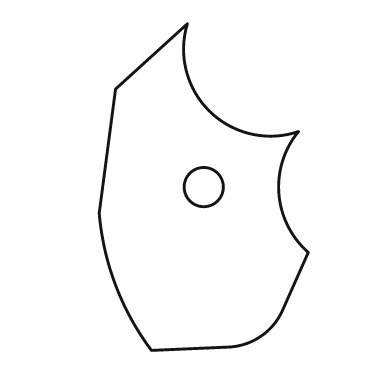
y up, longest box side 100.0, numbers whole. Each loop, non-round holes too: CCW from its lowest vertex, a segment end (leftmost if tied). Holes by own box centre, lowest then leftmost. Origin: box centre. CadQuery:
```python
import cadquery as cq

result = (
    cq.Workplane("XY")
    .moveTo(-16.0, -50.0)
    .lineTo(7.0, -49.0)
    .threePointArc((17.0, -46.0), (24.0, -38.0))
    .lineTo(32.0, -20.0)
    .threePointArc((23.0, -2.0), (29.0, 17.0))
    .threePointArc((2.0, 23.0), (-5.0, 50.0))
    .lineTo(-27.0, 30.0)
    .lineTo(-32.0, -8.0)
    .threePointArc((-27.0, -30.0), (-16.0, -50.0))
    .close()
    .moveTo(0.0, 0.0)
    .circle(6.0)
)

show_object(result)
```